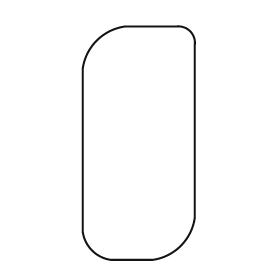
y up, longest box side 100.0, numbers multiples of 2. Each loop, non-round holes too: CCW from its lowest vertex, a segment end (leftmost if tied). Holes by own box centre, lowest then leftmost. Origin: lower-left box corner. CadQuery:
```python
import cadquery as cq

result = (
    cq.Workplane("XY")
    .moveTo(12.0, 0.0)
    .lineTo(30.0, 0.0)
    .threePointArc((42.0, 6.0), (48.0, 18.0))
    .lineTo(48.0, 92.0)
    .threePointArc((46.0, 98.0), (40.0, 100.0))
    .lineTo(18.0, 100.0)
    .threePointArc((6.0, 94.0), (0.0, 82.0))
    .lineTo(0.0, 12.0)
    .threePointArc((4.0, 4.0), (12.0, 0.0))
    .close()
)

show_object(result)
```